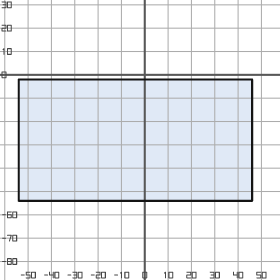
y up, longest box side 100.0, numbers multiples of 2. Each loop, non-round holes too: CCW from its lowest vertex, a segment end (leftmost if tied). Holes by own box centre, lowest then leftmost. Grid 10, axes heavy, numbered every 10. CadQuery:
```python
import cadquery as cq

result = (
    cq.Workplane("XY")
    .moveTo(-54.0, -54.0)
    .lineTo(46.0, -54.0)
    .lineTo(46.0, -2.0)
    .lineTo(-54.0, -2.0)
    .close()
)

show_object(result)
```